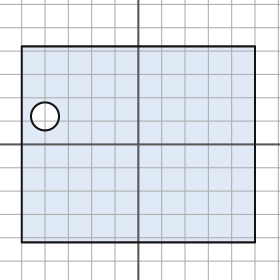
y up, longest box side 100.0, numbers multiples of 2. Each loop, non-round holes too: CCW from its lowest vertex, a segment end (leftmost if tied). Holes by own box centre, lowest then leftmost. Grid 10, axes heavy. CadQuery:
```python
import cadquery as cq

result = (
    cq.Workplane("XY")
    .moveTo(-50.0, -42.0)
    .lineTo(50.0, -42.0)
    .lineTo(50.0, 42.0)
    .lineTo(-50.0, 42.0)
    .close()
    .moveTo(-40.0, 12.0)
    .circle(6.0)
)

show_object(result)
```